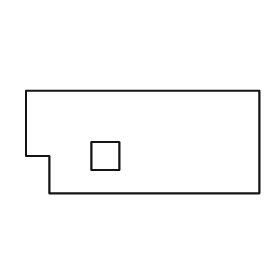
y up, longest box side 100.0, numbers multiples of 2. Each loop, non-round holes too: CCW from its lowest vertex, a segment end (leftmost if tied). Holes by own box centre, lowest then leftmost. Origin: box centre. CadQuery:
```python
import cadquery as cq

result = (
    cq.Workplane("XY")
    .moveTo(-40.0, -22.0)
    .lineTo(50.0, -22.0)
    .lineTo(50.0, 22.0)
    .lineTo(-50.0, 22.0)
    .lineTo(-50.0, -6.0)
    .lineTo(-40.0, -6.0)
    .close()
    .moveTo(-22.0, -12.0)
    .lineTo(-10.0, -12.0)
    .lineTo(-10.0, 0.0)
    .lineTo(-22.0, 0.0)
    .close()
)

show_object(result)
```